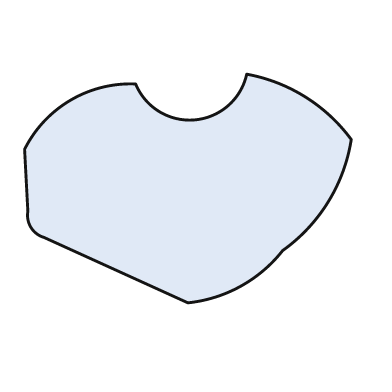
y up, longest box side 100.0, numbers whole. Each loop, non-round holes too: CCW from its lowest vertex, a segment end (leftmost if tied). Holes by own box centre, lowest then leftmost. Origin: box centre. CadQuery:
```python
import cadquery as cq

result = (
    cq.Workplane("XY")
    .moveTo(0.0, -35.0)
    .threePointArc((16.0, -30.0), (29.0, -19.0))
    .threePointArc((43.0, -4.0), (50.0, 15.0))
    .threePointArc((36.0, 28.0), (18.0, 35.0))
    .threePointArc((2.0, 21.0), (-16.0, 32.0))
    .threePointArc((-36.0, 27.0), (-50.0, 12.0))
    .lineTo(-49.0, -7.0)
    .threePointArc((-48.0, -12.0), (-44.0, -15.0))
    .close()
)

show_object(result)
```